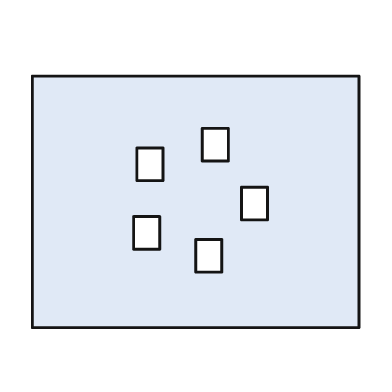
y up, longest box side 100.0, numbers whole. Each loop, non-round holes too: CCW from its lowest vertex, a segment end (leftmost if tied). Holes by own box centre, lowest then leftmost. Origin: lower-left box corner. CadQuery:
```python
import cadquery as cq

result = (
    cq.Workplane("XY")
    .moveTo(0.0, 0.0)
    .lineTo(100.0, 0.0)
    .lineTo(100.0, 77.0)
    .lineTo(0.0, 77.0)
    .close()
    .moveTo(50.0, 17.0)
    .lineTo(58.0, 17.0)
    .lineTo(58.0, 27.0)
    .lineTo(50.0, 27.0)
    .close()
    .moveTo(31.0, 24.0)
    .lineTo(39.0, 24.0)
    .lineTo(39.0, 34.0)
    .lineTo(31.0, 34.0)
    .close()
    .moveTo(64.0, 33.0)
    .lineTo(72.0, 33.0)
    .lineTo(72.0, 43.0)
    .lineTo(64.0, 43.0)
    .close()
    .moveTo(32.0, 45.0)
    .lineTo(40.0, 45.0)
    .lineTo(40.0, 55.0)
    .lineTo(32.0, 55.0)
    .close()
    .moveTo(52.0, 51.0)
    .lineTo(60.0, 51.0)
    .lineTo(60.0, 61.0)
    .lineTo(52.0, 61.0)
    .close()
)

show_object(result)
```